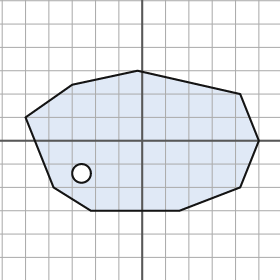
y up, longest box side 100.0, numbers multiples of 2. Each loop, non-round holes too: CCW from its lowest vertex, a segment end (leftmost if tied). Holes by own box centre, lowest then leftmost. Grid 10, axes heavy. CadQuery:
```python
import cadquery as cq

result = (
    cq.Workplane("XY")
    .moveTo(-22.0, -30.0)
    .lineTo(16.0, -30.0)
    .lineTo(42.0, -20.0)
    .lineTo(50.0, 0.0)
    .lineTo(42.0, 20.0)
    .lineTo(-2.0, 30.0)
    .lineTo(-30.0, 24.0)
    .lineTo(-50.0, 10.0)
    .lineTo(-38.0, -20.0)
    .close()
    .moveTo(-26.0, -14.0)
    .circle(4.0)
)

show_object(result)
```